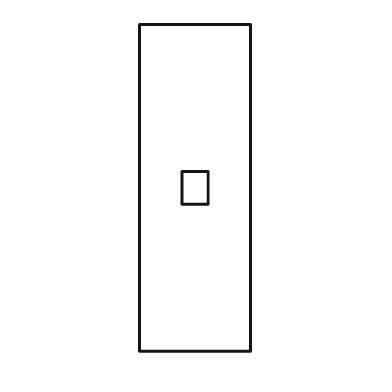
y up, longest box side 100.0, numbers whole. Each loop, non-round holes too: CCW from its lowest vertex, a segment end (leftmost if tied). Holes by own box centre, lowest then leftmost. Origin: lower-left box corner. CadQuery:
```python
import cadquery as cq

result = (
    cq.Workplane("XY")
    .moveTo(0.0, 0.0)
    .lineTo(34.0, 0.0)
    .lineTo(34.0, 100.0)
    .lineTo(0.0, 100.0)
    .close()
    .moveTo(13.0, 45.0)
    .lineTo(21.0, 45.0)
    .lineTo(21.0, 55.0)
    .lineTo(13.0, 55.0)
    .close()
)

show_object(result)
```